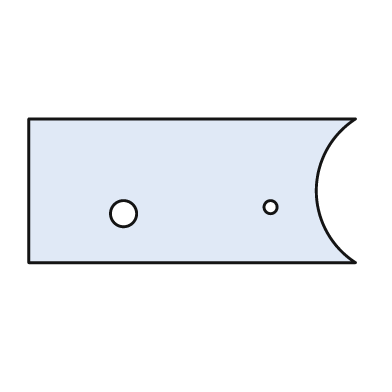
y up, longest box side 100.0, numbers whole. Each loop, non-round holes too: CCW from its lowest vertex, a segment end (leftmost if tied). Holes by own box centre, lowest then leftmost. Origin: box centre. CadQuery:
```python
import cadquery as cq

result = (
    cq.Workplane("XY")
    .moveTo(-50.0, -22.0)
    .lineTo(50.0, -22.0)
    .threePointArc((38.0, 0.0), (50.0, 22.0))
    .lineTo(-50.0, 22.0)
    .close()
    .moveTo(-21.0, -7.0)
    .circle(4.0)
    .moveTo(24.0, -5.0)
    .circle(2.0)
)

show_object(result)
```